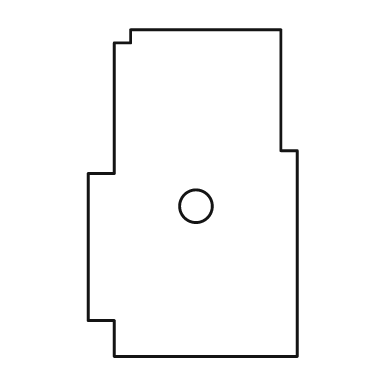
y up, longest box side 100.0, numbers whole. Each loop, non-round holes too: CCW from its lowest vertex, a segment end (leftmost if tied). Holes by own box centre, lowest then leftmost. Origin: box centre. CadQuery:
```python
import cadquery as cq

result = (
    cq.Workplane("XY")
    .moveTo(-24.0, -50.0)
    .lineTo(32.0, -50.0)
    .lineTo(32.0, 13.0)
    .lineTo(27.0, 13.0)
    .lineTo(27.0, 50.0)
    .lineTo(-19.0, 50.0)
    .lineTo(-19.0, 46.0)
    .lineTo(-24.0, 46.0)
    .lineTo(-24.0, 6.0)
    .lineTo(-32.0, 6.0)
    .lineTo(-32.0, -39.0)
    .lineTo(-24.0, -39.0)
    .close()
    .moveTo(1.0, -4.0)
    .circle(5.0)
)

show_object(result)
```